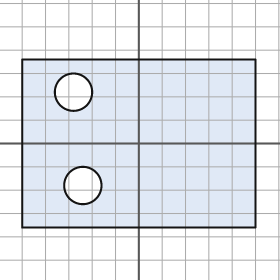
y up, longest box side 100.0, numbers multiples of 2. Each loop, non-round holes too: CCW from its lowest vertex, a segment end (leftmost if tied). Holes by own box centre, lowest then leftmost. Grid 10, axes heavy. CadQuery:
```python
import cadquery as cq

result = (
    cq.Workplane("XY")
    .moveTo(-50.0, -36.0)
    .lineTo(50.0, -36.0)
    .lineTo(50.0, 36.0)
    .lineTo(-50.0, 36.0)
    .close()
    .moveTo(-24.0, -18.0)
    .circle(8.0)
    .moveTo(-28.0, 22.0)
    .circle(8.0)
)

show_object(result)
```